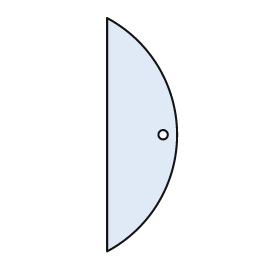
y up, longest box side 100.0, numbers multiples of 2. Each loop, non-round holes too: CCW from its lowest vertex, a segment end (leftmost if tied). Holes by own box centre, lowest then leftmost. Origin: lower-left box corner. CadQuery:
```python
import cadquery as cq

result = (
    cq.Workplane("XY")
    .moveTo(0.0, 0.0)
    .threePointArc((30.0, 50.0), (0.0, 100.0))
    .close()
    .moveTo(24.0, 50.0)
    .circle(2.0)
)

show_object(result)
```